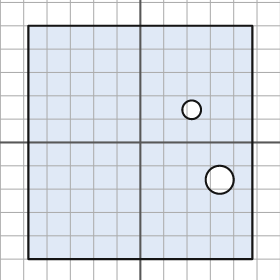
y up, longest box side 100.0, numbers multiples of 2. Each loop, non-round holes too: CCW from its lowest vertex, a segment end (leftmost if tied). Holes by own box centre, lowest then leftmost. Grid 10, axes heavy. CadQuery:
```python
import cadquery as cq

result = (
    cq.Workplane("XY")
    .moveTo(-48.0, -50.0)
    .lineTo(48.0, -50.0)
    .lineTo(48.0, 50.0)
    .lineTo(-48.0, 50.0)
    .close()
    .moveTo(34.0, -16.0)
    .circle(6.0)
    .moveTo(22.0, 14.0)
    .circle(4.0)
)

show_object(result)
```